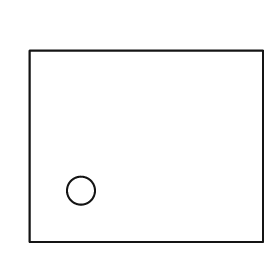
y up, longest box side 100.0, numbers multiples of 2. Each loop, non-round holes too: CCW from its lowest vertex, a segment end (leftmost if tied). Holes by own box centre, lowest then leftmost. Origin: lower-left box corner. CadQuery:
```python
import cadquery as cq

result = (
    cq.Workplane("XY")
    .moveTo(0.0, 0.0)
    .lineTo(100.0, 0.0)
    .lineTo(100.0, 82.0)
    .lineTo(0.0, 82.0)
    .close()
    .moveTo(22.0, 22.0)
    .circle(6.0)
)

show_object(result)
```